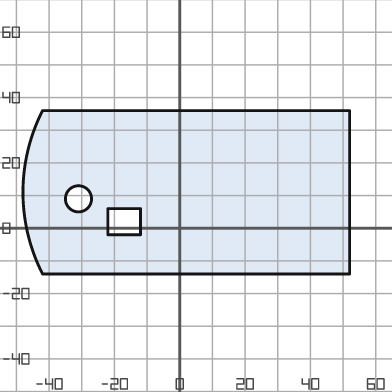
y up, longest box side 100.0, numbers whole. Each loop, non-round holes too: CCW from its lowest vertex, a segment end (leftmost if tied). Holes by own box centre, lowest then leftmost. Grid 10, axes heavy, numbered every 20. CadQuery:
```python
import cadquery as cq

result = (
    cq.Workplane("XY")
    .moveTo(-42.0, -14.0)
    .lineTo(52.0, -14.0)
    .lineTo(52.0, 36.0)
    .lineTo(-42.0, 36.0)
    .threePointArc((-48.0, 11.0), (-42.0, -14.0))
    .close()
    .moveTo(-22.0, -2.0)
    .lineTo(-12.0, -2.0)
    .lineTo(-12.0, 6.0)
    .lineTo(-22.0, 6.0)
    .close()
    .moveTo(-31.0, 9.0)
    .circle(4.0)
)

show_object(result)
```